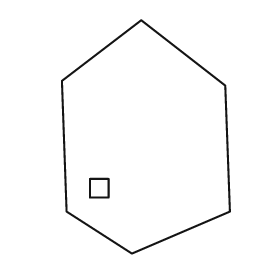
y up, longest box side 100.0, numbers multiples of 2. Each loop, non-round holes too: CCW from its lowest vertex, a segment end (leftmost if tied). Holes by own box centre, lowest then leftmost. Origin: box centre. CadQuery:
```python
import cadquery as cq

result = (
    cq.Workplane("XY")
    .moveTo(-6.0, -50.0)
    .lineTo(36.0, -32.0)
    .lineTo(34.0, 22.0)
    .lineTo(-2.0, 50.0)
    .lineTo(-36.0, 24.0)
    .lineTo(-34.0, -32.0)
    .close()
    .moveTo(-24.0, -26.0)
    .lineTo(-16.0, -26.0)
    .lineTo(-16.0, -18.0)
    .lineTo(-24.0, -18.0)
    .close()
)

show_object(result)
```